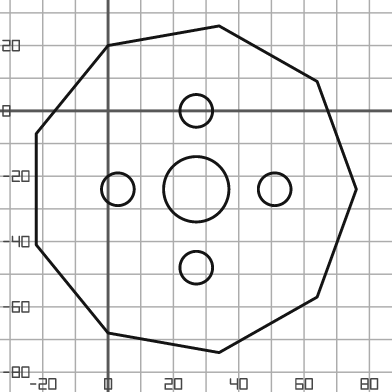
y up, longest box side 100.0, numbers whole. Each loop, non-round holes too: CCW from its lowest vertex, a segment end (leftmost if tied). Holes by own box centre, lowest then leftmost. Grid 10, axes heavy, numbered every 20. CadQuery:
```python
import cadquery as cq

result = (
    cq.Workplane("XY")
    .moveTo(34.0, -74.0)
    .lineTo(64.0, -57.0)
    .lineTo(76.0, -24.0)
    .lineTo(64.0, 9.0)
    .lineTo(34.0, 26.0)
    .lineTo(0.0, 20.0)
    .lineTo(-22.0, -7.0)
    .lineTo(-22.0, -41.0)
    .lineTo(0.0, -68.0)
    .close()
    .moveTo(27.0, -48.0)
    .circle(5.0)
    .moveTo(3.0, -24.0)
    .circle(5.0)
    .moveTo(27.0, -24.0)
    .circle(10.0)
    .moveTo(51.0, -24.0)
    .circle(5.0)
    .moveTo(27.0, 0.0)
    .circle(5.0)
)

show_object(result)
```